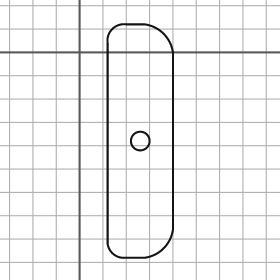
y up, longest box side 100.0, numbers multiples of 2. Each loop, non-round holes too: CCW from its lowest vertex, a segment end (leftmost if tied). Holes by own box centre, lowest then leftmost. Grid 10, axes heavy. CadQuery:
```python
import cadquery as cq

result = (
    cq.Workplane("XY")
    .moveTo(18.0, -88.0)
    .lineTo(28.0, -88.0)
    .threePointArc((36.0, -84.0), (40.0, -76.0))
    .lineTo(40.0, 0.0)
    .threePointArc((36.0, 8.0), (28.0, 12.0))
    .lineTo(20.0, 12.0)
    .threePointArc((14.0, 10.0), (12.0, 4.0))
    .lineTo(12.0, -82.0)
    .threePointArc((14.0, -86.0), (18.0, -88.0))
    .close()
    .moveTo(26.0, -38.0)
    .circle(4.0)
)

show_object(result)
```